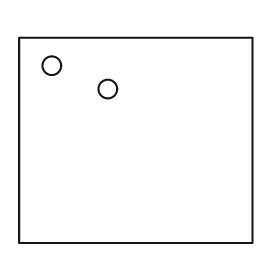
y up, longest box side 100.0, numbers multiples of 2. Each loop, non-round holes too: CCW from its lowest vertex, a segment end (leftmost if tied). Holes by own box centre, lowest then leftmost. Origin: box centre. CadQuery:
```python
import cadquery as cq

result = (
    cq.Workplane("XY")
    .moveTo(-50.0, -44.0)
    .lineTo(50.0, -44.0)
    .lineTo(50.0, 44.0)
    .lineTo(-50.0, 44.0)
    .close()
    .moveTo(-12.0, 22.0)
    .circle(4.0)
    .moveTo(-36.0, 32.0)
    .circle(4.0)
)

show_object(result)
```